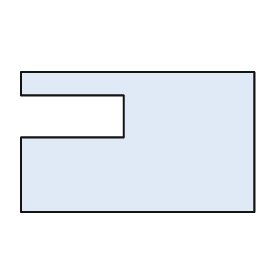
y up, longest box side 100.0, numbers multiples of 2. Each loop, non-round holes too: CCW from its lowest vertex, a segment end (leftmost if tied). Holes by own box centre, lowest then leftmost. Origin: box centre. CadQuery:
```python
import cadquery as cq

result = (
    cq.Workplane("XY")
    .moveTo(-50.0, -30.0)
    .lineTo(50.0, -30.0)
    .lineTo(50.0, 30.0)
    .lineTo(-50.0, 30.0)
    .lineTo(-50.0, 20.0)
    .lineTo(-6.0, 20.0)
    .lineTo(-6.0, 2.0)
    .lineTo(-50.0, 2.0)
    .close()
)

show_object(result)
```